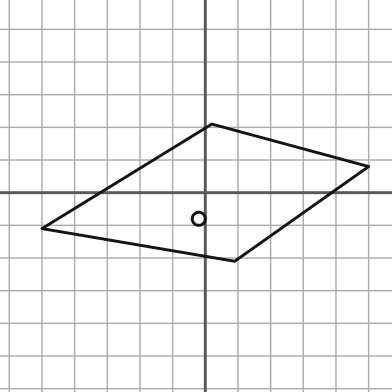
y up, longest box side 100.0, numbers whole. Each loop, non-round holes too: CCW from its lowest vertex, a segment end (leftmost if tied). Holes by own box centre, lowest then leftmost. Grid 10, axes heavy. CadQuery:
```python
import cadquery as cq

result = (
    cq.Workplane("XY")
    .moveTo(9.0, -21.0)
    .lineTo(50.0, 8.0)
    .lineTo(2.0, 21.0)
    .lineTo(-50.0, -11.0)
    .close()
    .moveTo(-2.0, -8.0)
    .circle(2.0)
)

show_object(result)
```